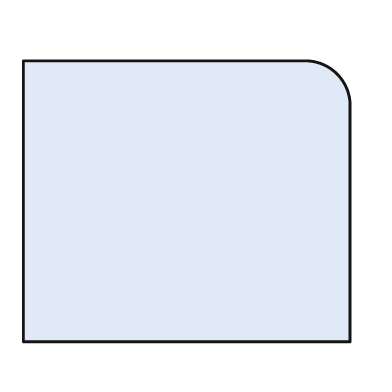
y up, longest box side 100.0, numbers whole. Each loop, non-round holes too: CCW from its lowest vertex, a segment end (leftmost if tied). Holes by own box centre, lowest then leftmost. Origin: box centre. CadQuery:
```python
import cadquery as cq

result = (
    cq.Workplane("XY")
    .moveTo(-50.0, -43.0)
    .lineTo(50.0, -43.0)
    .lineTo(50.0, 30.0)
    .threePointArc((46.0, 39.0), (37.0, 43.0))
    .lineTo(-50.0, 43.0)
    .close()
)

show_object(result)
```